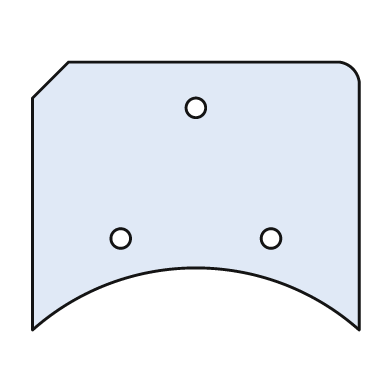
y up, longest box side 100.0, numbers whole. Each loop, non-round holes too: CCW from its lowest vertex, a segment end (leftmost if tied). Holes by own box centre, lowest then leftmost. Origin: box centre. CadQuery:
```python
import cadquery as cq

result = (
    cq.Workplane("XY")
    .moveTo(-50.0, -41.0)
    .threePointArc((0.0, -22.0), (50.0, -41.0))
    .lineTo(50.0, 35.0)
    .threePointArc((48.0, 39.0), (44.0, 41.0))
    .lineTo(-39.0, 41.0)
    .lineTo(-50.0, 30.0)
    .close()
    .moveTo(-23.0, -13.0)
    .circle(3.0)
    .moveTo(23.0, -13.0)
    .circle(3.0)
    .moveTo(0.0, 27.0)
    .circle(3.0)
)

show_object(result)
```